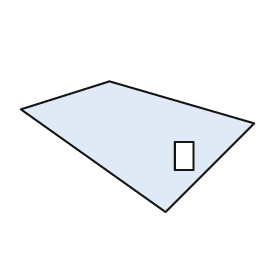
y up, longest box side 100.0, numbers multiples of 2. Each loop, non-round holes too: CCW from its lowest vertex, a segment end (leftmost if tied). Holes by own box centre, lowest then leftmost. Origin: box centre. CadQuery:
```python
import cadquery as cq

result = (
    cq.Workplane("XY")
    .moveTo(12.0, -28.0)
    .lineTo(50.0, 10.0)
    .lineTo(-12.0, 28.0)
    .lineTo(-50.0, 16.0)
    .close()
    .moveTo(16.0, -10.0)
    .lineTo(24.0, -10.0)
    .lineTo(24.0, 2.0)
    .lineTo(16.0, 2.0)
    .close()
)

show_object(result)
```